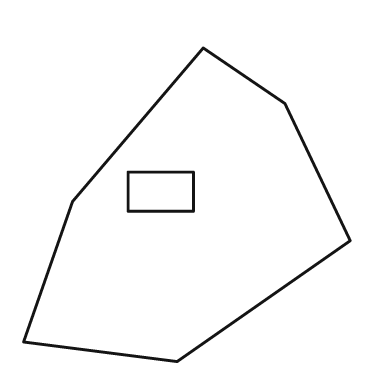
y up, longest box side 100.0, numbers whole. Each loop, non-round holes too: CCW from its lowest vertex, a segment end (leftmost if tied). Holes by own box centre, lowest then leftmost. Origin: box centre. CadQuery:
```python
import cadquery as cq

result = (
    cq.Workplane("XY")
    .moveTo(-3.0, -48.0)
    .lineTo(50.0, -11.0)
    .lineTo(30.0, 31.0)
    .lineTo(5.0, 48.0)
    .lineTo(-35.0, 1.0)
    .lineTo(-50.0, -42.0)
    .close()
    .moveTo(-18.0, -2.0)
    .lineTo(2.0, -2.0)
    .lineTo(2.0, 10.0)
    .lineTo(-18.0, 10.0)
    .close()
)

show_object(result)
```